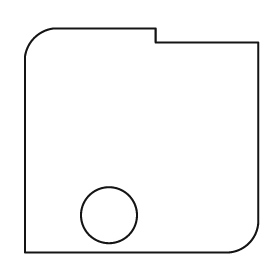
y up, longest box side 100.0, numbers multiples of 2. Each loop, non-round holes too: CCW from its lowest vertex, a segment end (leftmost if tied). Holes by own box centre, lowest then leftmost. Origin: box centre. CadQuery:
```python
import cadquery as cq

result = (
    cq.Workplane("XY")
    .moveTo(-50.0, -48.0)
    .lineTo(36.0, -48.0)
    .threePointArc((46.0, -44.0), (50.0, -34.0))
    .lineTo(50.0, 42.0)
    .lineTo(6.0, 42.0)
    .lineTo(6.0, 48.0)
    .lineTo(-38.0, 48.0)
    .threePointArc((-46.0, 44.0), (-50.0, 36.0))
    .close()
    .moveTo(-14.0, -32.0)
    .circle(12.0)
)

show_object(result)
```